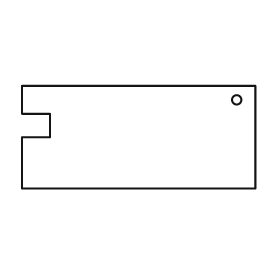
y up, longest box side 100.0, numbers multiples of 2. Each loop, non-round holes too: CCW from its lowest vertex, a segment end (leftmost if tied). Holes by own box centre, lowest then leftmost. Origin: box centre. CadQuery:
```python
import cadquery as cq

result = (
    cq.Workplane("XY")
    .moveTo(-50.0, -22.0)
    .lineTo(50.0, -22.0)
    .lineTo(50.0, 22.0)
    .lineTo(-50.0, 22.0)
    .lineTo(-50.0, 10.0)
    .lineTo(-38.0, 10.0)
    .lineTo(-38.0, 0.0)
    .lineTo(-50.0, 0.0)
    .close()
    .moveTo(42.0, 16.0)
    .circle(2.0)
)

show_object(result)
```